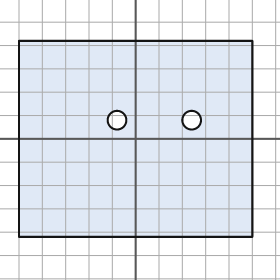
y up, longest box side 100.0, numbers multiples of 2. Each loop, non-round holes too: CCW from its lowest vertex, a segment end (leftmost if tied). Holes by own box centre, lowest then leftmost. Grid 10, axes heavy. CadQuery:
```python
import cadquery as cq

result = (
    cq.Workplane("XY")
    .moveTo(-50.0, -42.0)
    .lineTo(50.0, -42.0)
    .lineTo(50.0, 42.0)
    .lineTo(-50.0, 42.0)
    .close()
    .moveTo(-8.0, 8.0)
    .circle(4.0)
    .moveTo(24.0, 8.0)
    .circle(4.0)
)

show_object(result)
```